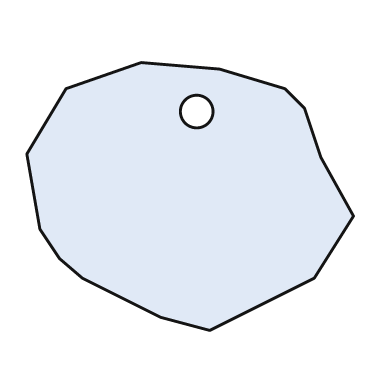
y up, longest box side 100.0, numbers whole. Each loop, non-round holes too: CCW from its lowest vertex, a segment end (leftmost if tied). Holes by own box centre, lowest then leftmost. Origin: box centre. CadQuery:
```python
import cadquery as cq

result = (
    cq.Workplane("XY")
    .moveTo(6.0, -41.0)
    .lineTo(38.0, -25.0)
    .lineTo(50.0, -6.0)
    .lineTo(40.0, 12.0)
    .lineTo(35.0, 27.0)
    .lineTo(29.0, 33.0)
    .lineTo(9.0, 39.0)
    .lineTo(-15.0, 41.0)
    .lineTo(-38.0, 33.0)
    .lineTo(-50.0, 13.0)
    .lineTo(-46.0, -10.0)
    .lineTo(-40.0, -19.0)
    .lineTo(-33.0, -25.0)
    .lineTo(-9.0, -37.0)
    .close()
    .moveTo(2.0, 26.0)
    .circle(5.0)
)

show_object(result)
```